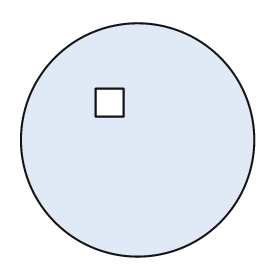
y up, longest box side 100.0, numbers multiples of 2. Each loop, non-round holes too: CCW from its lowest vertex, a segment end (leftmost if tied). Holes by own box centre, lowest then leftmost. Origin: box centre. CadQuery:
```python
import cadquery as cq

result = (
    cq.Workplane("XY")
    .moveTo(0.0, 0.0)
    .circle(50.0)
    .moveTo(-18.0, 10.0)
    .lineTo(-6.0, 10.0)
    .lineTo(-6.0, 22.0)
    .lineTo(-18.0, 22.0)
    .close()
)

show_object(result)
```